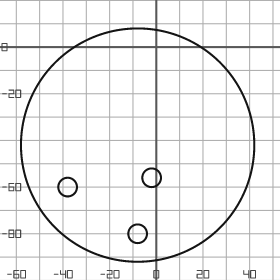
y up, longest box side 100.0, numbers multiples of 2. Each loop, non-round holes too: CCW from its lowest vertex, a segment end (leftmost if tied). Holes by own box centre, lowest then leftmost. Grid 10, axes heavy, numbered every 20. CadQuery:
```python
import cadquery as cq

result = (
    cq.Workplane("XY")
    .moveTo(-8.0, -42.0)
    .circle(50.0)
    .moveTo(-8.0, -80.0)
    .circle(4.0)
    .moveTo(-38.0, -60.0)
    .circle(4.0)
    .moveTo(-2.0, -56.0)
    .circle(4.0)
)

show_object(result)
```